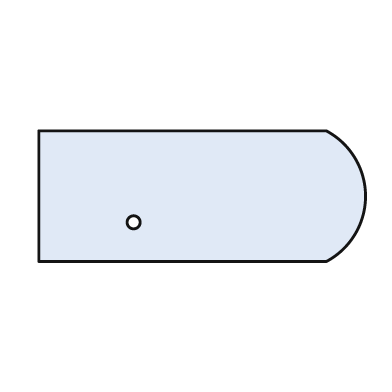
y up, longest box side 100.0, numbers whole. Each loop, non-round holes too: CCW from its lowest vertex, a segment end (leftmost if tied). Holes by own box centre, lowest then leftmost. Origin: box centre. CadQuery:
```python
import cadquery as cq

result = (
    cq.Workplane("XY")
    .moveTo(-50.0, -20.0)
    .lineTo(38.0, -20.0)
    .threePointArc((50.0, 0.0), (38.0, 20.0))
    .lineTo(-50.0, 20.0)
    .close()
    .moveTo(-21.0, -8.0)
    .circle(2.0)
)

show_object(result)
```